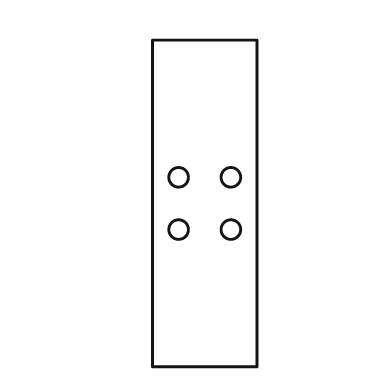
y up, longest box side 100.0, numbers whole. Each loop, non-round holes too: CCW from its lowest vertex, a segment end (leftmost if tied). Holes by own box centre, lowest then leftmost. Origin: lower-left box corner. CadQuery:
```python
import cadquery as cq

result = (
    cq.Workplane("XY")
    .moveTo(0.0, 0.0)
    .lineTo(32.0, 0.0)
    .lineTo(32.0, 100.0)
    .lineTo(0.0, 100.0)
    .close()
    .moveTo(8.0, 42.0)
    .circle(3.0)
    .moveTo(24.0, 42.0)
    .circle(3.0)
    .moveTo(8.0, 58.0)
    .circle(3.0)
    .moveTo(24.0, 58.0)
    .circle(3.0)
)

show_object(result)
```